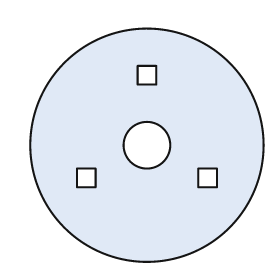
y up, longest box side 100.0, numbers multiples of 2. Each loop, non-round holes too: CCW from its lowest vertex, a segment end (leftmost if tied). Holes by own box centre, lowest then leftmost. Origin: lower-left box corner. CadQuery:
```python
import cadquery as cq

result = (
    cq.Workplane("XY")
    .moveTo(50.0, 50.0)
    .circle(50.0)
    .moveTo(20.0, 32.0)
    .lineTo(28.0, 32.0)
    .lineTo(28.0, 40.0)
    .lineTo(20.0, 40.0)
    .close()
    .moveTo(72.0, 32.0)
    .lineTo(80.0, 32.0)
    .lineTo(80.0, 40.0)
    .lineTo(72.0, 40.0)
    .close()
    .moveTo(50.0, 50.0)
    .circle(10.0)
    .moveTo(46.0, 76.0)
    .lineTo(54.0, 76.0)
    .lineTo(54.0, 84.0)
    .lineTo(46.0, 84.0)
    .close()
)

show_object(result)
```